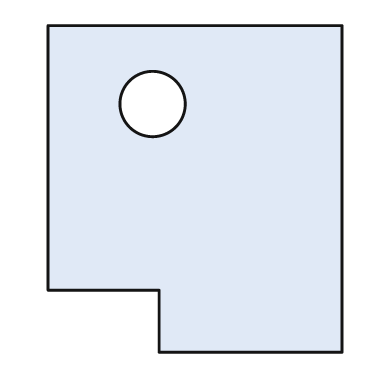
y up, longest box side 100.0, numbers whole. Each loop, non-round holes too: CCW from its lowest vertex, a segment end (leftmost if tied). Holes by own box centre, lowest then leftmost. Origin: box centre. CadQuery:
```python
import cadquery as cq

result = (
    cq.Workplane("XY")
    .moveTo(-11.0, -50.0)
    .lineTo(45.0, -50.0)
    .lineTo(45.0, 50.0)
    .lineTo(-45.0, 50.0)
    .lineTo(-45.0, -31.0)
    .lineTo(-11.0, -31.0)
    .close()
    .moveTo(-13.0, 26.0)
    .circle(10.0)
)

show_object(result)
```